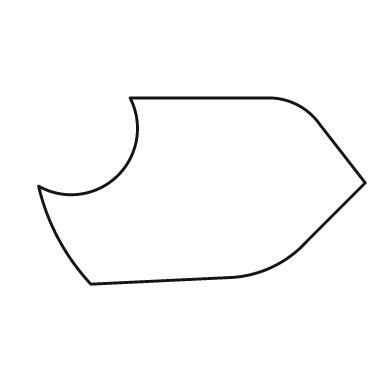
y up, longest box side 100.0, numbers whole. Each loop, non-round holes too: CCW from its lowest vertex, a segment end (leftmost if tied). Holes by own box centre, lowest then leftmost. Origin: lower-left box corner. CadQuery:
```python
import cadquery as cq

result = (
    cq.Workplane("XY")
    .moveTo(16.0, 0.0)
    .lineTo(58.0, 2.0)
    .threePointArc((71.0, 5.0), (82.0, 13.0))
    .lineTo(100.0, 31.0)
    .lineTo(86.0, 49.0)
    .threePointArc((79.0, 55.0), (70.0, 57.0))
    .lineTo(28.0, 57.0)
    .threePointArc((24.0, 33.0), (0.0, 30.0))
    .threePointArc((6.0, 14.0), (16.0, 0.0))
    .close()
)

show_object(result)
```